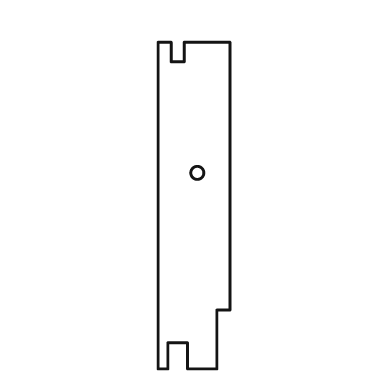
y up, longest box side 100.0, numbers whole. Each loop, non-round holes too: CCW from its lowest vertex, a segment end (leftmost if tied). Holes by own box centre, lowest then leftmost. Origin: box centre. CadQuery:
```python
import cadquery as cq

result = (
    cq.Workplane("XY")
    .moveTo(-11.0, -50.0)
    .lineTo(-8.0, -50.0)
    .lineTo(-8.0, -42.0)
    .lineTo(-2.0, -42.0)
    .lineTo(-2.0, -50.0)
    .lineTo(7.0, -50.0)
    .lineTo(7.0, -32.0)
    .lineTo(11.0, -32.0)
    .lineTo(11.0, 50.0)
    .lineTo(-3.0, 50.0)
    .lineTo(-3.0, 44.0)
    .lineTo(-7.0, 44.0)
    .lineTo(-7.0, 50.0)
    .lineTo(-11.0, 50.0)
    .close()
    .moveTo(1.0, 10.0)
    .circle(2.0)
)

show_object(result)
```